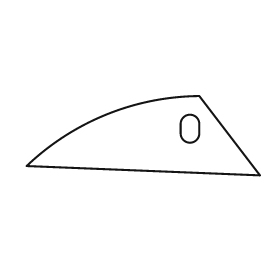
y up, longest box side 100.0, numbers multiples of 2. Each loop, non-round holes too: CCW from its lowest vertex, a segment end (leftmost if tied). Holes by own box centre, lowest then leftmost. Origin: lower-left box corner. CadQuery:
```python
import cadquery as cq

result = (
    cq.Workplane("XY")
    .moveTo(100.0, 0.0)
    .lineTo(74.0, 34.0)
    .threePointArc((34.0, 26.0), (0.0, 4.0))
    .close()
    .moveTo(66.0, 18.0)
    .threePointArc((70.0, 14.0), (74.0, 18.0))
    .lineTo(74.0, 22.0)
    .threePointArc((70.0, 26.0), (66.0, 22.0))
    .close()
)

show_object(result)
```